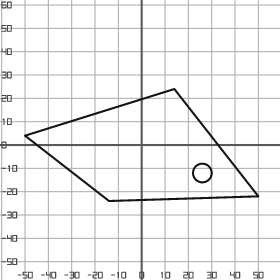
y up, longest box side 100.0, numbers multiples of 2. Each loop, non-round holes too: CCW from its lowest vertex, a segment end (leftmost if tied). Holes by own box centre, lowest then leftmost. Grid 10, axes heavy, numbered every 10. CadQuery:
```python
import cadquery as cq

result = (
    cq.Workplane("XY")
    .moveTo(-14.0, -24.0)
    .lineTo(50.0, -22.0)
    .lineTo(14.0, 24.0)
    .lineTo(-50.0, 4.0)
    .close()
    .moveTo(26.0, -12.0)
    .circle(4.0)
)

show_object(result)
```